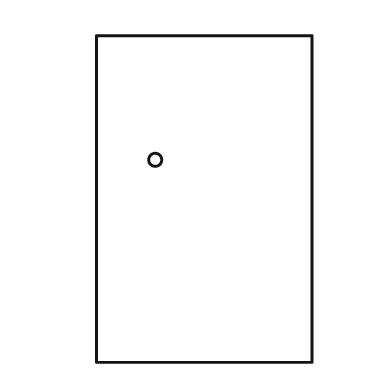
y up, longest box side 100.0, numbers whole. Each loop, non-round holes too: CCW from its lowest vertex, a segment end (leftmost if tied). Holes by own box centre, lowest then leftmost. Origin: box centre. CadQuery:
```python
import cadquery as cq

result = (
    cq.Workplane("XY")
    .moveTo(-33.0, -50.0)
    .lineTo(33.0, -50.0)
    .lineTo(33.0, 50.0)
    .lineTo(-33.0, 50.0)
    .close()
    .moveTo(-15.0, 12.0)
    .circle(2.0)
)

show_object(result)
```